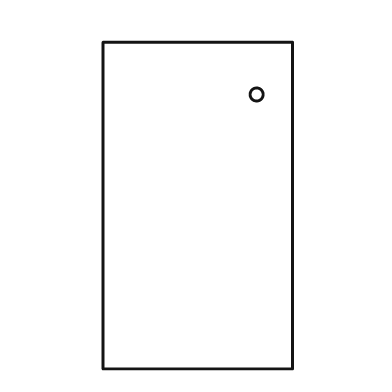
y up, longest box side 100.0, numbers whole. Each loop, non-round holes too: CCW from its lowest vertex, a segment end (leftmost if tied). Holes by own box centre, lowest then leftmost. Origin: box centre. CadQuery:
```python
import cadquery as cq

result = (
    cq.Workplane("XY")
    .moveTo(-29.0, -50.0)
    .lineTo(29.0, -50.0)
    .lineTo(29.0, 50.0)
    .lineTo(-29.0, 50.0)
    .close()
    .moveTo(18.0, 34.0)
    .circle(2.0)
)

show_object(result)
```